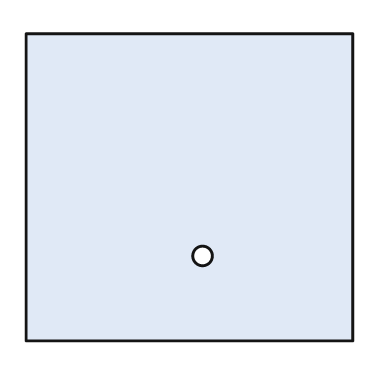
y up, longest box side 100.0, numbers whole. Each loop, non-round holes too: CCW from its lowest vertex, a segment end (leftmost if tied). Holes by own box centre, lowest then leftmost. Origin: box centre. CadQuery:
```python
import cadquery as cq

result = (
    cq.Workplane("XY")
    .moveTo(-50.0, -47.0)
    .lineTo(50.0, -47.0)
    .lineTo(50.0, 47.0)
    .lineTo(-50.0, 47.0)
    .close()
    .moveTo(4.0, -21.0)
    .circle(3.0)
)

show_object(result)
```